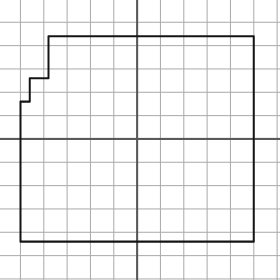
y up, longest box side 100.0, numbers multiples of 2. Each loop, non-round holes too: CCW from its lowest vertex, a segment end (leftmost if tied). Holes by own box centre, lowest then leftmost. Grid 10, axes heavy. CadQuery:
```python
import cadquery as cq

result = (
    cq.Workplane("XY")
    .moveTo(-50.0, -44.0)
    .lineTo(50.0, -44.0)
    .lineTo(50.0, 44.0)
    .lineTo(-38.0, 44.0)
    .lineTo(-38.0, 26.0)
    .lineTo(-46.0, 26.0)
    .lineTo(-46.0, 16.0)
    .lineTo(-50.0, 16.0)
    .close()
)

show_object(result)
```